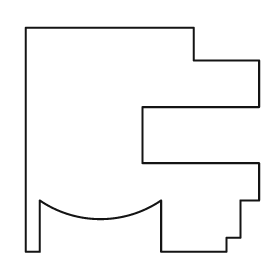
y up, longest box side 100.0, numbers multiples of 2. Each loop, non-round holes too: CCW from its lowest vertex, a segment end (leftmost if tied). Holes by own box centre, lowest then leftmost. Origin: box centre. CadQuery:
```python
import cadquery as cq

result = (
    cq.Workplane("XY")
    .moveTo(-50.0, -48.0)
    .lineTo(-44.0, -48.0)
    .lineTo(-44.0, -26.0)
    .threePointArc((-18.0, -34.0), (8.0, -26.0))
    .lineTo(8.0, -48.0)
    .lineTo(36.0, -48.0)
    .lineTo(36.0, -42.0)
    .lineTo(42.0, -42.0)
    .lineTo(42.0, -26.0)
    .lineTo(50.0, -26.0)
    .lineTo(50.0, -10.0)
    .lineTo(0.0, -10.0)
    .lineTo(0.0, 14.0)
    .lineTo(50.0, 14.0)
    .lineTo(50.0, 34.0)
    .lineTo(22.0, 34.0)
    .lineTo(22.0, 48.0)
    .lineTo(-50.0, 48.0)
    .close()
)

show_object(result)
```